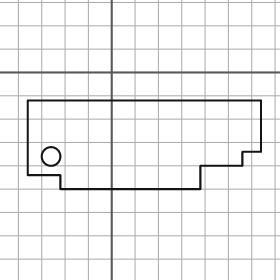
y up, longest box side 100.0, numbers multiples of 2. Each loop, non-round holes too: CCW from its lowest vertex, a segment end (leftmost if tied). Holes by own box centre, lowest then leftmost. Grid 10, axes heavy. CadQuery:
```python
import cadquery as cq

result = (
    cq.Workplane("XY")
    .moveTo(-22.0, -50.0)
    .lineTo(38.0, -50.0)
    .lineTo(38.0, -40.0)
    .lineTo(56.0, -40.0)
    .lineTo(56.0, -34.0)
    .lineTo(64.0, -34.0)
    .lineTo(64.0, -12.0)
    .lineTo(-36.0, -12.0)
    .lineTo(-36.0, -44.0)
    .lineTo(-22.0, -44.0)
    .close()
    .moveTo(-26.0, -36.0)
    .circle(4.0)
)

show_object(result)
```